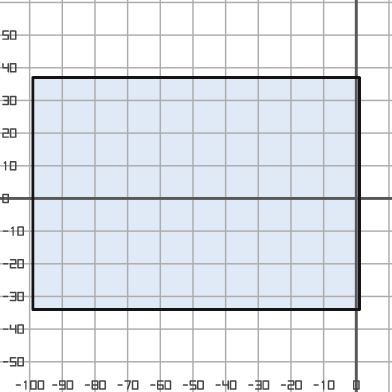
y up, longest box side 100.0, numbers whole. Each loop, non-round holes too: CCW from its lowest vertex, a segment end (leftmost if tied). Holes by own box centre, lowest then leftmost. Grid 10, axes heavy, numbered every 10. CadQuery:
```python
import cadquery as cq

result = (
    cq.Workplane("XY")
    .moveTo(-99.0, -34.0)
    .lineTo(1.0, -34.0)
    .lineTo(1.0, 37.0)
    .lineTo(-99.0, 37.0)
    .close()
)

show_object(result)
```